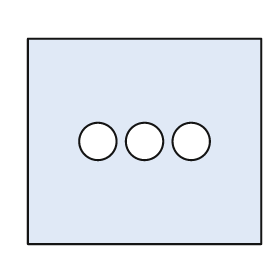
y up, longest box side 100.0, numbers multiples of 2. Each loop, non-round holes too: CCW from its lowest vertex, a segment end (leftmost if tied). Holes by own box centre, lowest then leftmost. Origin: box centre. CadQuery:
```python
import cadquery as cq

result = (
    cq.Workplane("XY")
    .moveTo(-50.0, -44.0)
    .lineTo(50.0, -44.0)
    .lineTo(50.0, 44.0)
    .lineTo(-50.0, 44.0)
    .close()
    .moveTo(-20.0, 0.0)
    .circle(8.0)
    .moveTo(0.0, 0.0)
    .circle(8.0)
    .moveTo(20.0, 0.0)
    .circle(8.0)
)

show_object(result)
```